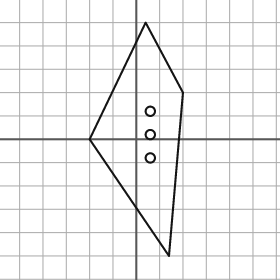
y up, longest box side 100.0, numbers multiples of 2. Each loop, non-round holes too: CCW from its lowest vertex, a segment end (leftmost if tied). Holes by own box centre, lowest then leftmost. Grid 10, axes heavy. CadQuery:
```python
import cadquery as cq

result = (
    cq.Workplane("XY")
    .moveTo(14.0, -50.0)
    .lineTo(20.0, 20.0)
    .lineTo(4.0, 50.0)
    .lineTo(-20.0, 0.0)
    .close()
    .moveTo(6.0, -8.0)
    .circle(2.0)
    .moveTo(6.0, 2.0)
    .circle(2.0)
    .moveTo(6.0, 12.0)
    .circle(2.0)
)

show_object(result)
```